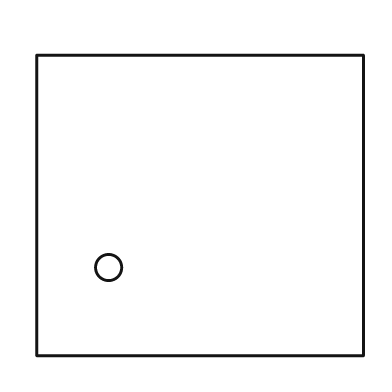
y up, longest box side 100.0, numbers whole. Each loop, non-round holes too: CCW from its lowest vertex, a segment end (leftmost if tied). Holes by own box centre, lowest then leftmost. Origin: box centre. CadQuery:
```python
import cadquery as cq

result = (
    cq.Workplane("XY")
    .moveTo(-50.0, -46.0)
    .lineTo(50.0, -46.0)
    .lineTo(50.0, 46.0)
    .lineTo(-50.0, 46.0)
    .close()
    .moveTo(-28.0, -19.0)
    .circle(4.0)
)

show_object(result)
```